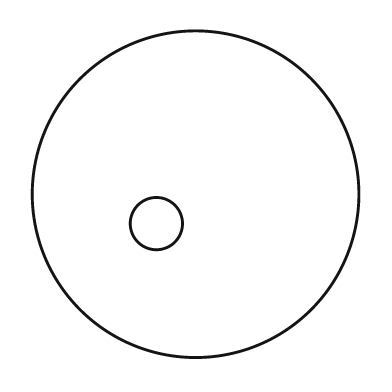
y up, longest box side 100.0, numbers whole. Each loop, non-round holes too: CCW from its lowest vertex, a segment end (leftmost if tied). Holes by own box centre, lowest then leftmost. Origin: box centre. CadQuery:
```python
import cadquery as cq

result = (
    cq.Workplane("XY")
    .moveTo(0.0, 0.0)
    .circle(50.0)
    .moveTo(-12.0, -9.0)
    .circle(8.0)
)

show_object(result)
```